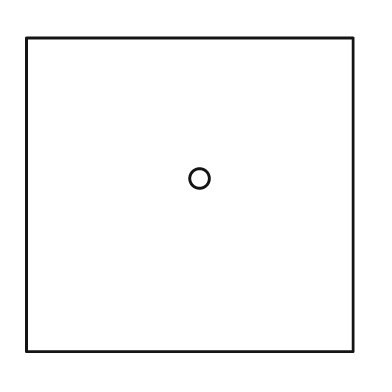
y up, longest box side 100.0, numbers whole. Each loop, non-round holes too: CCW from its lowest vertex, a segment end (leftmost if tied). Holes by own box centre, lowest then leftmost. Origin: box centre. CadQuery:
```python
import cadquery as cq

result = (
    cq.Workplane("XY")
    .moveTo(-50.0, -48.0)
    .lineTo(50.0, -48.0)
    .lineTo(50.0, 48.0)
    .lineTo(-50.0, 48.0)
    .close()
    .moveTo(3.0, 5.0)
    .circle(3.0)
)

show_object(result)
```